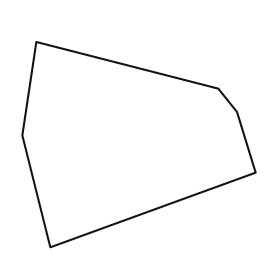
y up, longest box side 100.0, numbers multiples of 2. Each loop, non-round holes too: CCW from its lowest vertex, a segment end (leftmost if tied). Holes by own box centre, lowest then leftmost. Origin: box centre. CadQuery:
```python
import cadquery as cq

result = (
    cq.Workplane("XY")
    .moveTo(-38.0, -44.0)
    .lineTo(50.0, -12.0)
    .lineTo(42.0, 14.0)
    .lineTo(34.0, 24.0)
    .lineTo(-44.0, 44.0)
    .lineTo(-50.0, 4.0)
    .close()
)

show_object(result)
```